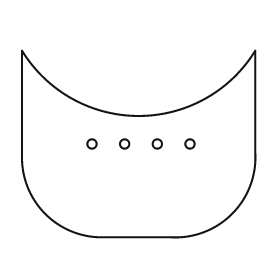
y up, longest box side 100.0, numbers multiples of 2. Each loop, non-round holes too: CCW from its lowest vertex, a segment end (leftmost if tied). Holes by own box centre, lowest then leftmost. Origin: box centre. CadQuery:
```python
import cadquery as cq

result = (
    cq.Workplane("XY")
    .moveTo(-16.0, -40.0)
    .lineTo(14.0, -40.0)
    .threePointArc((40.0, -30.0), (50.0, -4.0))
    .lineTo(50.0, 40.0)
    .threePointArc((0.0, 12.0), (-50.0, 40.0))
    .lineTo(-50.0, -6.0)
    .threePointArc((-40.0, -30.0), (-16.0, -40.0))
    .close()
    .moveTo(-20.0, 0.0)
    .circle(2.0)
    .moveTo(-6.0, 0.0)
    .circle(2.0)
    .moveTo(8.0, 0.0)
    .circle(2.0)
    .moveTo(22.0, 0.0)
    .circle(2.0)
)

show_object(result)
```